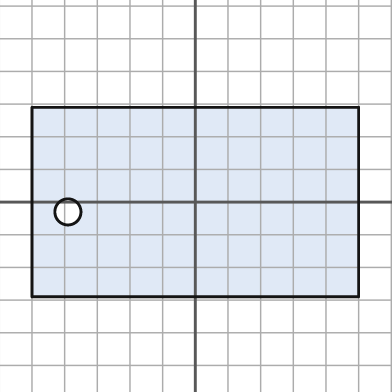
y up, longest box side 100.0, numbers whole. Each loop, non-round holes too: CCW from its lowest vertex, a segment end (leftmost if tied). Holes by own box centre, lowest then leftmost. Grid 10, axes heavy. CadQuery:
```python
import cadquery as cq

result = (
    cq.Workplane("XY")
    .moveTo(-50.0, -29.0)
    .lineTo(50.0, -29.0)
    .lineTo(50.0, 29.0)
    .lineTo(-50.0, 29.0)
    .close()
    .moveTo(-39.0, -3.0)
    .circle(4.0)
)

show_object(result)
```